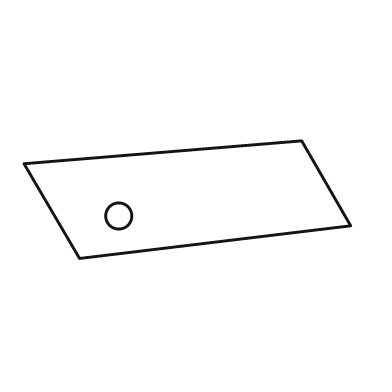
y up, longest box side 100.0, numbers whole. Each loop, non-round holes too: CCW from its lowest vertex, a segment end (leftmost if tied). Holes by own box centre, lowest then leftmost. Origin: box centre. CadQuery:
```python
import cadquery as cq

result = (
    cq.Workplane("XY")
    .moveTo(-33.0, -18.0)
    .lineTo(50.0, -8.0)
    .lineTo(35.0, 18.0)
    .lineTo(-50.0, 11.0)
    .close()
    .moveTo(-21.0, -5.0)
    .circle(4.0)
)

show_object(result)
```